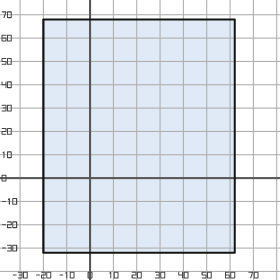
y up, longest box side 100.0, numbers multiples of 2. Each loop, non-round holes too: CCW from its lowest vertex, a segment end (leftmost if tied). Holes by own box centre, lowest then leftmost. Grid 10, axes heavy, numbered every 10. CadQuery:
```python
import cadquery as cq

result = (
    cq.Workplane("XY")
    .moveTo(-20.0, -32.0)
    .lineTo(62.0, -32.0)
    .lineTo(62.0, 68.0)
    .lineTo(-20.0, 68.0)
    .close()
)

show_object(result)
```